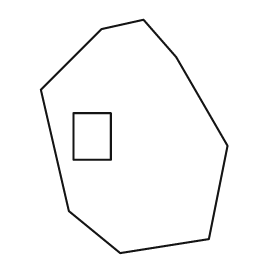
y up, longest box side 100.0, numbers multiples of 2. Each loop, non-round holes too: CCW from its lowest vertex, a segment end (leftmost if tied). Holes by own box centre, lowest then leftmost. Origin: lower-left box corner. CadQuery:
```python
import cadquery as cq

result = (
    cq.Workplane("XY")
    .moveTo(34.0, 0.0)
    .lineTo(72.0, 6.0)
    .lineTo(80.0, 46.0)
    .lineTo(58.0, 84.0)
    .lineTo(44.0, 100.0)
    .lineTo(26.0, 96.0)
    .lineTo(0.0, 70.0)
    .lineTo(12.0, 18.0)
    .close()
    .moveTo(14.0, 40.0)
    .lineTo(30.0, 40.0)
    .lineTo(30.0, 60.0)
    .lineTo(14.0, 60.0)
    .close()
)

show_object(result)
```